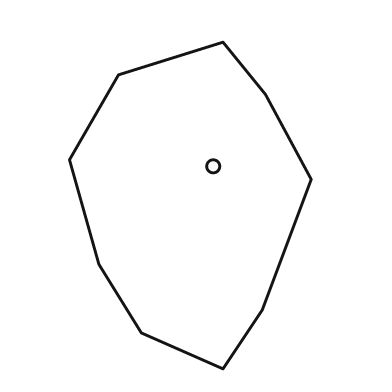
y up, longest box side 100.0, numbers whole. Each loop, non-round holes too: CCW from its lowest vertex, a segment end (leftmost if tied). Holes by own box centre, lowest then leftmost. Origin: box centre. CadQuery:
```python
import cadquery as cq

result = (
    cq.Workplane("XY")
    .moveTo(10.0, -50.0)
    .lineTo(22.0, -32.0)
    .lineTo(37.0, 8.0)
    .lineTo(23.0, 34.0)
    .lineTo(10.0, 50.0)
    .lineTo(-22.0, 40.0)
    .lineTo(-37.0, 14.0)
    .lineTo(-28.0, -18.0)
    .lineTo(-15.0, -39.0)
    .close()
    .moveTo(7.0, 12.0)
    .circle(2.0)
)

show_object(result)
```